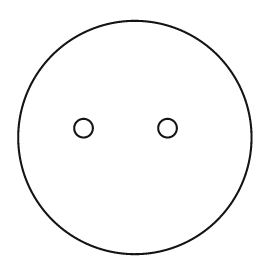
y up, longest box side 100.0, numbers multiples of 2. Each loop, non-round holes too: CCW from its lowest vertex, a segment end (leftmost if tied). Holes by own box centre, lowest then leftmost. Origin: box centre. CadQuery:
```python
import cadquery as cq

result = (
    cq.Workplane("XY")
    .moveTo(0.0, 0.0)
    .circle(50.0)
    .moveTo(-22.0, 4.0)
    .circle(4.0)
    .moveTo(14.0, 4.0)
    .circle(4.0)
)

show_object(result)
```